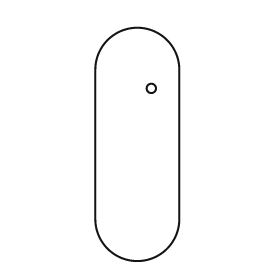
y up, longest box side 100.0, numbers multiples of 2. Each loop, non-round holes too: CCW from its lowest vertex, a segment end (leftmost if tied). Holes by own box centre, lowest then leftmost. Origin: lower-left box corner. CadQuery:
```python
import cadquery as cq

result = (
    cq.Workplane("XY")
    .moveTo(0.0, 18.0)
    .threePointArc((18.0, 0.0), (36.0, 18.0))
    .lineTo(36.0, 82.0)
    .threePointArc((18.0, 100.0), (0.0, 82.0))
    .close()
    .moveTo(24.0, 74.0)
    .circle(2.0)
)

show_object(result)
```